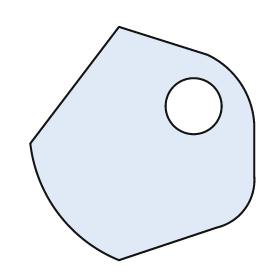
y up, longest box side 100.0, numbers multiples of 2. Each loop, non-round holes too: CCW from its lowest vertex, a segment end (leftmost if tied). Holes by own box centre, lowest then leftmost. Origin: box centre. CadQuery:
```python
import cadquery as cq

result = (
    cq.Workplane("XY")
    .moveTo(-10.0, -50.0)
    .lineTo(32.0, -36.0)
    .threePointArc((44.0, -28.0), (48.0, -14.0))
    .lineTo(48.0, 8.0)
    .threePointArc((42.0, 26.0), (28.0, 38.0))
    .lineTo(-10.0, 50.0)
    .lineTo(-48.0, 0.0)
    .threePointArc((-36.0, -30.0), (-10.0, -50.0))
    .close()
    .moveTo(22.0, 16.0)
    .circle(12.0)
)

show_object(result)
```